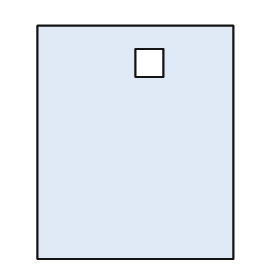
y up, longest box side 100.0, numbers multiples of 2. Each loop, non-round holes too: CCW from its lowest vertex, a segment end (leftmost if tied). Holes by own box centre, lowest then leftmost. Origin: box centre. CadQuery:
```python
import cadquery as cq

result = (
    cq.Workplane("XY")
    .moveTo(-42.0, -50.0)
    .lineTo(42.0, -50.0)
    .lineTo(42.0, 50.0)
    .lineTo(-42.0, 50.0)
    .close()
    .moveTo(0.0, 28.0)
    .lineTo(12.0, 28.0)
    .lineTo(12.0, 40.0)
    .lineTo(0.0, 40.0)
    .close()
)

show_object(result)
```